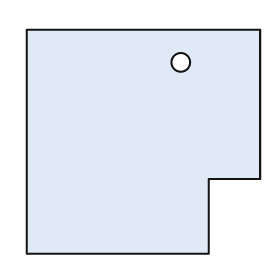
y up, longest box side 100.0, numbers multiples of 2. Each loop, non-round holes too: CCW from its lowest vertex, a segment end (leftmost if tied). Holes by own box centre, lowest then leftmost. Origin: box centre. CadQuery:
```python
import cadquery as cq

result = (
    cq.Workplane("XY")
    .moveTo(-50.0, -48.0)
    .lineTo(28.0, -48.0)
    .lineTo(28.0, -16.0)
    .lineTo(50.0, -16.0)
    .lineTo(50.0, 48.0)
    .lineTo(-50.0, 48.0)
    .close()
    .moveTo(16.0, 34.0)
    .circle(4.0)
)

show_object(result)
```